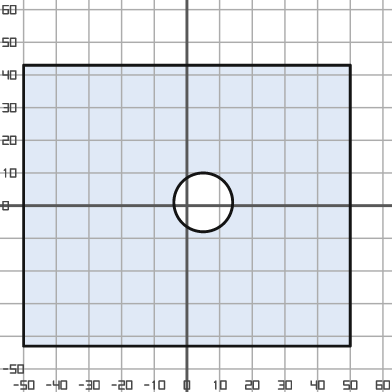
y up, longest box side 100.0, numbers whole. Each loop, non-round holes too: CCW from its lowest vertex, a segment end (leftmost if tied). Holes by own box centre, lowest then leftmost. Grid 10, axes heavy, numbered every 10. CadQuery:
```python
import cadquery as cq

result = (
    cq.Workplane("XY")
    .moveTo(-50.0, -43.0)
    .lineTo(50.0, -43.0)
    .lineTo(50.0, 43.0)
    .lineTo(-50.0, 43.0)
    .close()
    .moveTo(5.0, 1.0)
    .circle(9.0)
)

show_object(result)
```